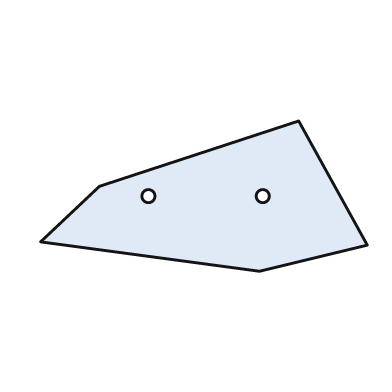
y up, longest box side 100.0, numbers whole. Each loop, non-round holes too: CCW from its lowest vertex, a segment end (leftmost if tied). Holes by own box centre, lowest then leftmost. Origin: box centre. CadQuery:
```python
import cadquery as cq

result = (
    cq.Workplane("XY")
    .moveTo(17.0, -23.0)
    .lineTo(50.0, -15.0)
    .lineTo(29.0, 23.0)
    .lineTo(-32.0, 3.0)
    .lineTo(-50.0, -14.0)
    .close()
    .moveTo(-17.0, 0.0)
    .circle(2.0)
    .moveTo(18.0, 0.0)
    .circle(2.0)
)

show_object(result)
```